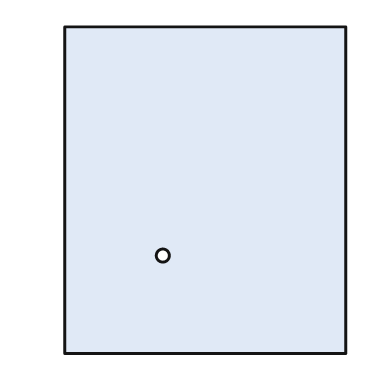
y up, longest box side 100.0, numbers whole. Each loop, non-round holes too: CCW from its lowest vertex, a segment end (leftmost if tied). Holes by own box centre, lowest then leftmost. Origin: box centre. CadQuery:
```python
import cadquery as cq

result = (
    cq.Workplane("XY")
    .moveTo(-43.0, -50.0)
    .lineTo(43.0, -50.0)
    .lineTo(43.0, 50.0)
    .lineTo(-43.0, 50.0)
    .close()
    .moveTo(-13.0, -20.0)
    .circle(2.0)
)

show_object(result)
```